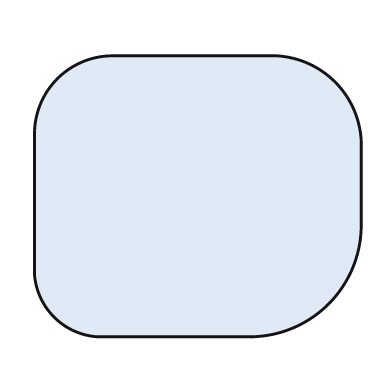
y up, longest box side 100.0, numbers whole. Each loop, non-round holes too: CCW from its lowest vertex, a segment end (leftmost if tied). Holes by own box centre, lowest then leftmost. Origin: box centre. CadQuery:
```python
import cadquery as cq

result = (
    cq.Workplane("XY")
    .moveTo(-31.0, -43.0)
    .lineTo(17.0, -43.0)
    .threePointArc((40.0, -33.0), (50.0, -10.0))
    .lineTo(50.0, 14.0)
    .threePointArc((42.0, 35.0), (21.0, 43.0))
    .lineTo(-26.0, 43.0)
    .threePointArc((-43.0, 36.0), (-50.0, 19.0))
    .lineTo(-50.0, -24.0)
    .threePointArc((-44.0, -37.0), (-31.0, -43.0))
    .close()
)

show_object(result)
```